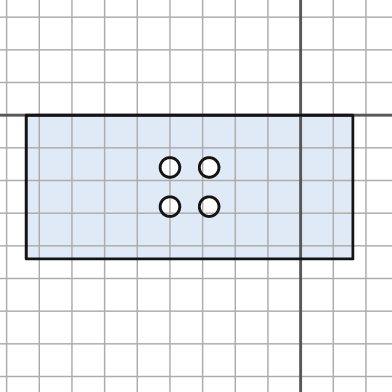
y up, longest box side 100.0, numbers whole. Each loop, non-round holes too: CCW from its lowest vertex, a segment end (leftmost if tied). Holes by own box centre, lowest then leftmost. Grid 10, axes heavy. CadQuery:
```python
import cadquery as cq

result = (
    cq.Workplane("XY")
    .moveTo(-84.0, -44.0)
    .lineTo(16.0, -44.0)
    .lineTo(16.0, 0.0)
    .lineTo(-84.0, 0.0)
    .close()
    .moveTo(-40.0, -28.0)
    .circle(3.0)
    .moveTo(-28.0, -28.0)
    .circle(3.0)
    .moveTo(-40.0, -16.0)
    .circle(3.0)
    .moveTo(-28.0, -16.0)
    .circle(3.0)
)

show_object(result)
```